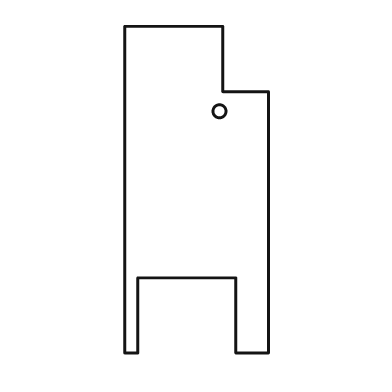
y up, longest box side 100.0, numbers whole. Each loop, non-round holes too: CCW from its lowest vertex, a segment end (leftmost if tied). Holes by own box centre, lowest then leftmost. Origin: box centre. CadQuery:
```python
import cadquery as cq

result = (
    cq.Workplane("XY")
    .moveTo(-22.0, -50.0)
    .lineTo(-18.0, -50.0)
    .lineTo(-18.0, -27.0)
    .lineTo(12.0, -27.0)
    .lineTo(12.0, -50.0)
    .lineTo(22.0, -50.0)
    .lineTo(22.0, 30.0)
    .lineTo(8.0, 30.0)
    .lineTo(8.0, 50.0)
    .lineTo(-22.0, 50.0)
    .close()
    .moveTo(7.0, 24.0)
    .circle(2.0)
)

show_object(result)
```